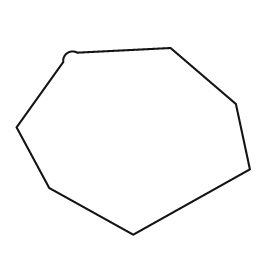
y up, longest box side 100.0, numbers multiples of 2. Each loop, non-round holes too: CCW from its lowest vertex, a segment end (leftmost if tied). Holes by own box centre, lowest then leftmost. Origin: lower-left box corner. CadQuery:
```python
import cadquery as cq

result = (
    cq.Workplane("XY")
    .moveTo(50.0, 0.0)
    .lineTo(100.0, 28.0)
    .lineTo(94.0, 56.0)
    .lineTo(66.0, 80.0)
    .lineTo(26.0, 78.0)
    .threePointArc((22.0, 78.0), (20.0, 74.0))
    .lineTo(0.0, 46.0)
    .lineTo(14.0, 20.0)
    .close()
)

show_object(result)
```